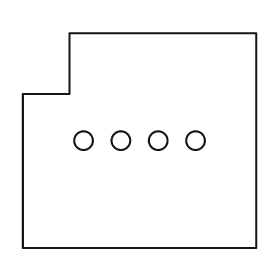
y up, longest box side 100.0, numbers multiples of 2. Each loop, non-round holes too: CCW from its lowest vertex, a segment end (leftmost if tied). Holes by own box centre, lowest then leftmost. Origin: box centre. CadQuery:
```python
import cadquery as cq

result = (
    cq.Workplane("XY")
    .moveTo(-50.0, -46.0)
    .lineTo(50.0, -46.0)
    .lineTo(50.0, 46.0)
    .lineTo(-30.0, 46.0)
    .lineTo(-30.0, 20.0)
    .lineTo(-50.0, 20.0)
    .close()
    .moveTo(-24.0, 0.0)
    .circle(4.0)
    .moveTo(-8.0, 0.0)
    .circle(4.0)
    .moveTo(8.0, 0.0)
    .circle(4.0)
    .moveTo(24.0, 0.0)
    .circle(4.0)
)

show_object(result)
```